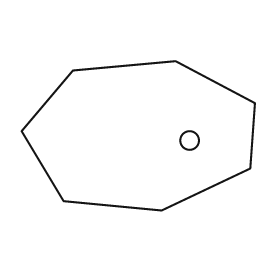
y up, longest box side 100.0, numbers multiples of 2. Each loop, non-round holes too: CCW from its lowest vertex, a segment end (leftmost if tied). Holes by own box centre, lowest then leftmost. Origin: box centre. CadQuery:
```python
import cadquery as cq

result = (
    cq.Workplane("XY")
    .moveTo(10.0, -32.0)
    .lineTo(48.0, -14.0)
    .lineTo(50.0, 14.0)
    .lineTo(16.0, 32.0)
    .lineTo(-28.0, 28.0)
    .lineTo(-50.0, 2.0)
    .lineTo(-32.0, -28.0)
    .close()
    .moveTo(22.0, -2.0)
    .circle(4.0)
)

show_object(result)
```